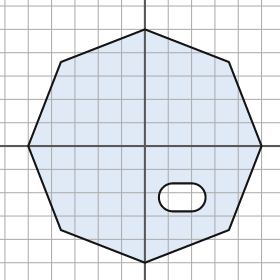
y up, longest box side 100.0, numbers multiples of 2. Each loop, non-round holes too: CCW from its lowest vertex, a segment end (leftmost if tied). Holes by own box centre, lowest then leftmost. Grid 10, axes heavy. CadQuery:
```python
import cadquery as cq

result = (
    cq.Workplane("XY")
    .moveTo(0.0, -50.0)
    .lineTo(36.0, -36.0)
    .lineTo(50.0, 0.0)
    .lineTo(36.0, 36.0)
    .lineTo(0.0, 50.0)
    .lineTo(-36.0, 36.0)
    .lineTo(-50.0, 0.0)
    .lineTo(-36.0, -36.0)
    .close()
    .moveTo(12.0, -28.0)
    .lineTo(20.0, -28.0)
    .threePointArc((26.0, -22.0), (20.0, -16.0))
    .lineTo(12.0, -16.0)
    .threePointArc((6.0, -22.0), (12.0, -28.0))
    .close()
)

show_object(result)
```